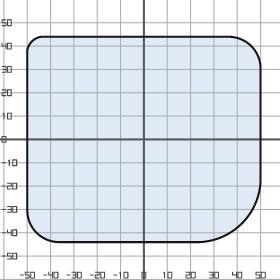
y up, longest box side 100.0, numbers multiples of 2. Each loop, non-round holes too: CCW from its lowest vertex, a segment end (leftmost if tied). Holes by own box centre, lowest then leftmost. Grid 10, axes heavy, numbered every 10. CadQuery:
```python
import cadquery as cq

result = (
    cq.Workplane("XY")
    .moveTo(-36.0, -44.0)
    .lineTo(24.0, -44.0)
    .threePointArc((42.0, -36.0), (50.0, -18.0))
    .lineTo(50.0, 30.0)
    .threePointArc((46.0, 40.0), (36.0, 44.0))
    .lineTo(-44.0, 44.0)
    .threePointArc((-48.0, 42.0), (-50.0, 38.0))
    .lineTo(-50.0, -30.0)
    .threePointArc((-46.0, -40.0), (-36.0, -44.0))
    .close()
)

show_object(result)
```